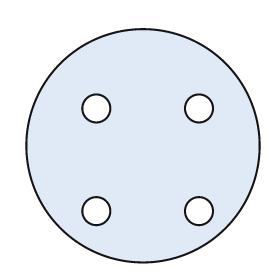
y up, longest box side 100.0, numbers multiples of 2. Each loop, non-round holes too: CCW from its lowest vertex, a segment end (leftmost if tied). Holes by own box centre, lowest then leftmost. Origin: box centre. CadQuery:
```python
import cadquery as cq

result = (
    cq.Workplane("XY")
    .moveTo(0.0, 0.0)
    .circle(50.0)
    .moveTo(-20.0, -28.0)
    .circle(6.0)
    .moveTo(24.0, -28.0)
    .circle(6.0)
    .moveTo(-20.0, 16.0)
    .circle(6.0)
    .moveTo(24.0, 16.0)
    .circle(6.0)
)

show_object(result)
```